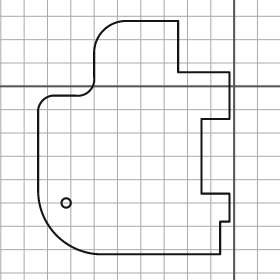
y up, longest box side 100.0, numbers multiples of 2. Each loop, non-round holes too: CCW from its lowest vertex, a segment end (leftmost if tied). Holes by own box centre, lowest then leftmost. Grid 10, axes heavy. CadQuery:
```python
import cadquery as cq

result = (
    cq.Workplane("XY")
    .moveTo(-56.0, -72.0)
    .lineTo(-6.0, -72.0)
    .lineTo(-6.0, -58.0)
    .lineTo(-2.0, -58.0)
    .lineTo(-2.0, -46.0)
    .lineTo(-14.0, -46.0)
    .lineTo(-14.0, -14.0)
    .lineTo(-2.0, -14.0)
    .lineTo(-2.0, 6.0)
    .lineTo(-24.0, 6.0)
    .lineTo(-24.0, 28.0)
    .lineTo(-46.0, 28.0)
    .threePointArc((-56.0, 24.0), (-60.0, 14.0))
    .lineTo(-60.0, 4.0)
    .threePointArc((-62.0, -2.0), (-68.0, -4.0))
    .lineTo(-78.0, -4.0)
    .threePointArc((-82.0, -6.0), (-84.0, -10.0))
    .lineTo(-84.0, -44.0)
    .threePointArc((-76.0, -64.0), (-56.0, -72.0))
    .close()
    .moveTo(-72.0, -50.0)
    .circle(2.0)
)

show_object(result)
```